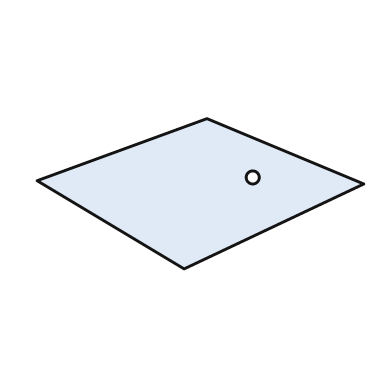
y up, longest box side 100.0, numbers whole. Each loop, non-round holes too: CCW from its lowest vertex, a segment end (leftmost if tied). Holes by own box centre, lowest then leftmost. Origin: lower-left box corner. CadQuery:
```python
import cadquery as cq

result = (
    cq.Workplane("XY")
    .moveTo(45.0, 0.0)
    .lineTo(100.0, 26.0)
    .lineTo(52.0, 46.0)
    .lineTo(0.0, 27.0)
    .close()
    .moveTo(66.0, 28.0)
    .circle(2.0)
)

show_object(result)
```